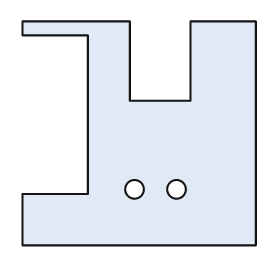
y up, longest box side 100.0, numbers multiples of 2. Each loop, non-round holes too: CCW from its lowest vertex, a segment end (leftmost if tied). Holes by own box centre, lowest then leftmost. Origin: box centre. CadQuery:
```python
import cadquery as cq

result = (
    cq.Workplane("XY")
    .moveTo(-50.0, -48.0)
    .lineTo(50.0, -48.0)
    .lineTo(50.0, 48.0)
    .lineTo(22.0, 48.0)
    .lineTo(22.0, 14.0)
    .lineTo(-4.0, 14.0)
    .lineTo(-4.0, 48.0)
    .lineTo(-50.0, 48.0)
    .lineTo(-50.0, 42.0)
    .lineTo(-22.0, 42.0)
    .lineTo(-22.0, -26.0)
    .lineTo(-50.0, -26.0)
    .close()
    .moveTo(-2.0, -24.0)
    .circle(4.0)
    .moveTo(16.0, -24.0)
    .circle(4.0)
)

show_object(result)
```